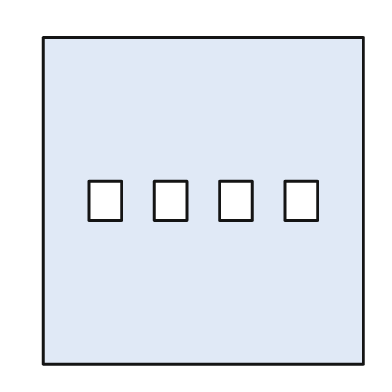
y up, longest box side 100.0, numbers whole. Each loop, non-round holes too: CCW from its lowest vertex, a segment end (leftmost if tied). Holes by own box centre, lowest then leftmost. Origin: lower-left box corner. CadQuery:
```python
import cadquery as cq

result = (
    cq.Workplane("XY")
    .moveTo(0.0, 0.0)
    .lineTo(98.0, 0.0)
    .lineTo(98.0, 100.0)
    .lineTo(0.0, 100.0)
    .close()
    .moveTo(14.0, 44.0)
    .lineTo(24.0, 44.0)
    .lineTo(24.0, 56.0)
    .lineTo(14.0, 56.0)
    .close()
    .moveTo(34.0, 44.0)
    .lineTo(44.0, 44.0)
    .lineTo(44.0, 56.0)
    .lineTo(34.0, 56.0)
    .close()
    .moveTo(54.0, 44.0)
    .lineTo(64.0, 44.0)
    .lineTo(64.0, 56.0)
    .lineTo(54.0, 56.0)
    .close()
    .moveTo(74.0, 44.0)
    .lineTo(84.0, 44.0)
    .lineTo(84.0, 56.0)
    .lineTo(74.0, 56.0)
    .close()
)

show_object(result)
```